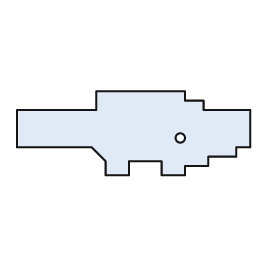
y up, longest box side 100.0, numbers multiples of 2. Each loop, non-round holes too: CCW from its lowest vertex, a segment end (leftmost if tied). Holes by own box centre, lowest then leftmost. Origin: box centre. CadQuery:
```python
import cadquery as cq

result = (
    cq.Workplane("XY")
    .moveTo(-12.0, -18.0)
    .lineTo(-2.0, -18.0)
    .lineTo(-2.0, -12.0)
    .lineTo(12.0, -12.0)
    .lineTo(12.0, -18.0)
    .lineTo(22.0, -18.0)
    .lineTo(22.0, -14.0)
    .lineTo(32.0, -14.0)
    .lineTo(32.0, -10.0)
    .lineTo(44.0, -10.0)
    .lineTo(44.0, -6.0)
    .lineTo(50.0, -6.0)
    .lineTo(50.0, 10.0)
    .lineTo(30.0, 10.0)
    .lineTo(30.0, 14.0)
    .lineTo(22.0, 14.0)
    .lineTo(22.0, 18.0)
    .lineTo(-16.0, 18.0)
    .lineTo(-16.0, 10.0)
    .lineTo(-50.0, 10.0)
    .lineTo(-50.0, -6.0)
    .lineTo(-18.0, -6.0)
    .lineTo(-12.0, -12.0)
    .close()
    .moveTo(20.0, -2.0)
    .circle(2.0)
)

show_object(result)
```